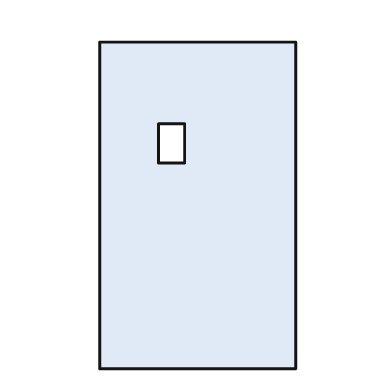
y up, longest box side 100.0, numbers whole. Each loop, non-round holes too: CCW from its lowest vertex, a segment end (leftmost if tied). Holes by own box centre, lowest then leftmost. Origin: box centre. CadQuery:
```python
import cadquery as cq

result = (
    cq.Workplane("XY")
    .moveTo(-30.0, -50.0)
    .lineTo(30.0, -50.0)
    .lineTo(30.0, 50.0)
    .lineTo(-30.0, 50.0)
    .close()
    .moveTo(-12.0, 13.0)
    .lineTo(-4.0, 13.0)
    .lineTo(-4.0, 25.0)
    .lineTo(-12.0, 25.0)
    .close()
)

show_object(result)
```